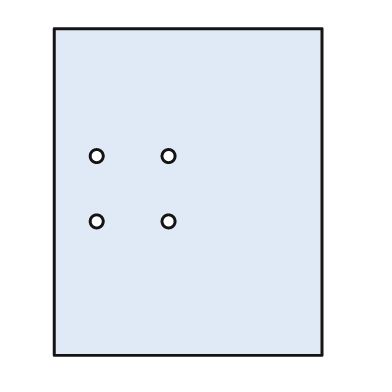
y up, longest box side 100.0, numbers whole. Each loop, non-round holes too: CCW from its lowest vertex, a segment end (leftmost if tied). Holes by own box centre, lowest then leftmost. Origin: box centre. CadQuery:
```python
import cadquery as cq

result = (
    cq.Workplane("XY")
    .moveTo(-41.0, -50.0)
    .lineTo(41.0, -50.0)
    .lineTo(41.0, 50.0)
    .lineTo(-41.0, 50.0)
    .close()
    .moveTo(-28.0, -9.0)
    .circle(2.0)
    .moveTo(-6.0, -9.0)
    .circle(2.0)
    .moveTo(-28.0, 11.0)
    .circle(2.0)
    .moveTo(-6.0, 11.0)
    .circle(2.0)
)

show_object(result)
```